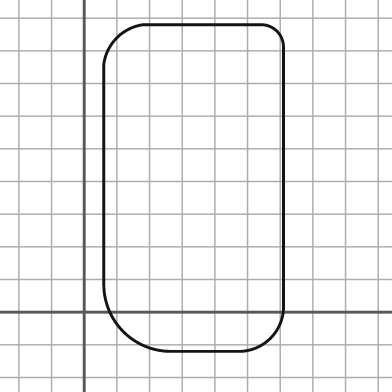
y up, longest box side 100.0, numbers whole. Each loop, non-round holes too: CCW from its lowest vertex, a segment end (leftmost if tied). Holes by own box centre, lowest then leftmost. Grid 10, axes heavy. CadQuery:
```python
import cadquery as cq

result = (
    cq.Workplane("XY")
    .moveTo(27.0, -12.0)
    .lineTo(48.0, -12.0)
    .threePointArc((57.0, -8.0), (61.0, 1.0))
    .lineTo(61.0, 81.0)
    .threePointArc((59.0, 86.0), (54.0, 88.0))
    .lineTo(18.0, 88.0)
    .threePointArc((10.0, 84.0), (6.0, 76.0))
    .lineTo(6.0, 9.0)
    .threePointArc((12.0, -6.0), (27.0, -12.0))
    .close()
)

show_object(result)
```